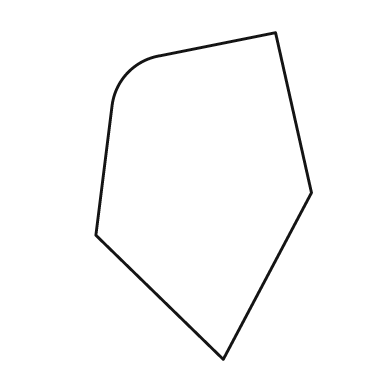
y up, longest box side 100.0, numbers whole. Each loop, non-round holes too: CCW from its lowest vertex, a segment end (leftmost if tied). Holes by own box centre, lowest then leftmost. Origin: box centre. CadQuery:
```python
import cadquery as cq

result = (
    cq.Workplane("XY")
    .moveTo(6.0, -50.0)
    .lineTo(33.0, 1.0)
    .lineTo(22.0, 50.0)
    .lineTo(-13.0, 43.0)
    .threePointArc((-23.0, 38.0), (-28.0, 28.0))
    .lineTo(-33.0, -12.0)
    .close()
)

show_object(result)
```